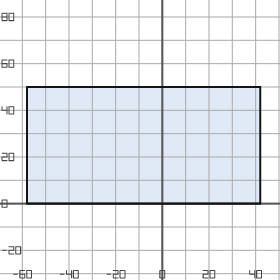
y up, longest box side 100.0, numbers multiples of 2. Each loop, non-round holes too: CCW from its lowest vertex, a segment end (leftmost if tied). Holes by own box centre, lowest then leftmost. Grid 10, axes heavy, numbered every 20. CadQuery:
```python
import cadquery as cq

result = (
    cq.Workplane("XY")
    .moveTo(-58.0, 0.0)
    .lineTo(42.0, 0.0)
    .lineTo(42.0, 50.0)
    .lineTo(-58.0, 50.0)
    .close()
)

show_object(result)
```